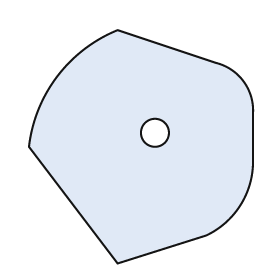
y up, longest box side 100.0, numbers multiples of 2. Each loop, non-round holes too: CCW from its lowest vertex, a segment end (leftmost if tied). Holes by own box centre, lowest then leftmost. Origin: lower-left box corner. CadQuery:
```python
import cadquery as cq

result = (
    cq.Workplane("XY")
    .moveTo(38.0, 0.0)
    .lineTo(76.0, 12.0)
    .threePointArc((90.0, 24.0), (96.0, 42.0))
    .lineTo(96.0, 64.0)
    .threePointArc((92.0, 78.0), (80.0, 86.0))
    .lineTo(38.0, 100.0)
    .threePointArc((12.0, 80.0), (0.0, 50.0))
    .close()
    .moveTo(54.0, 56.0)
    .circle(6.0)
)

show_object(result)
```